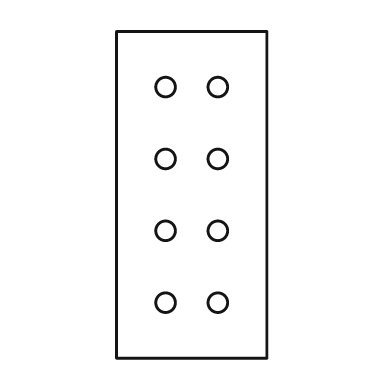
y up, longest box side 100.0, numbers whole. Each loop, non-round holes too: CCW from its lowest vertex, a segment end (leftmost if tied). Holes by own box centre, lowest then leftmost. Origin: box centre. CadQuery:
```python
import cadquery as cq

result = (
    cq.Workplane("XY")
    .moveTo(-23.0, -50.0)
    .lineTo(23.0, -50.0)
    .lineTo(23.0, 50.0)
    .lineTo(-23.0, 50.0)
    .close()
    .moveTo(-8.0, -33.0)
    .circle(3.0)
    .moveTo(8.0, -33.0)
    .circle(3.0)
    .moveTo(-8.0, -11.0)
    .circle(3.0)
    .moveTo(8.0, -11.0)
    .circle(3.0)
    .moveTo(-8.0, 11.0)
    .circle(3.0)
    .moveTo(8.0, 11.0)
    .circle(3.0)
    .moveTo(-8.0, 33.0)
    .circle(3.0)
    .moveTo(8.0, 33.0)
    .circle(3.0)
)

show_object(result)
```